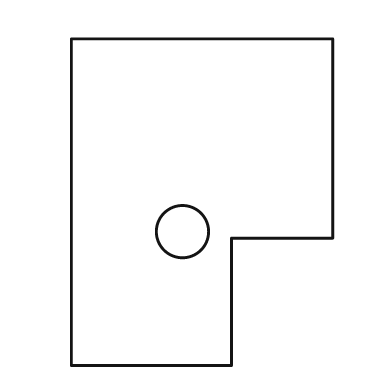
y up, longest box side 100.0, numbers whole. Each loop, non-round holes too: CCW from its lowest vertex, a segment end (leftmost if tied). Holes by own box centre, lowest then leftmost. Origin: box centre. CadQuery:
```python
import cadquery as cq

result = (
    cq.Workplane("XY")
    .moveTo(-40.0, -50.0)
    .lineTo(9.0, -50.0)
    .lineTo(9.0, -11.0)
    .lineTo(40.0, -11.0)
    .lineTo(40.0, 50.0)
    .lineTo(-40.0, 50.0)
    .close()
    .moveTo(-6.0, -9.0)
    .circle(8.0)
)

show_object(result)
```